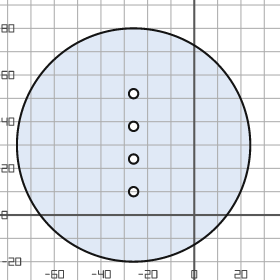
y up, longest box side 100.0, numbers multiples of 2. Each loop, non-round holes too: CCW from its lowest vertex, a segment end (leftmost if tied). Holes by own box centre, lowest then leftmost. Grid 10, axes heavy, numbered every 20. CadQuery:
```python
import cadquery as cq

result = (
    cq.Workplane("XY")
    .moveTo(-26.0, 30.0)
    .circle(50.0)
    .moveTo(-26.0, 10.0)
    .circle(2.0)
    .moveTo(-26.0, 24.0)
    .circle(2.0)
    .moveTo(-26.0, 38.0)
    .circle(2.0)
    .moveTo(-26.0, 52.0)
    .circle(2.0)
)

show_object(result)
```